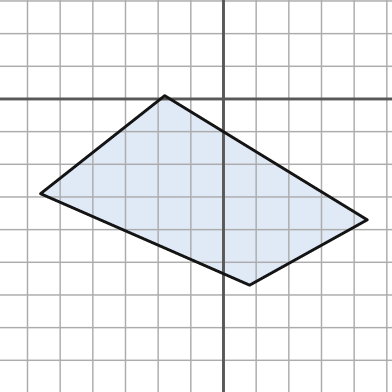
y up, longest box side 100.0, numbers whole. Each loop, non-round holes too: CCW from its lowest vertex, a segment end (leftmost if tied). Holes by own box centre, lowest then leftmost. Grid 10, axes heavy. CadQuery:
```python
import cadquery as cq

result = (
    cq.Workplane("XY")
    .moveTo(8.0, -57.0)
    .lineTo(44.0, -37.0)
    .lineTo(-18.0, 1.0)
    .lineTo(-56.0, -29.0)
    .close()
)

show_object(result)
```